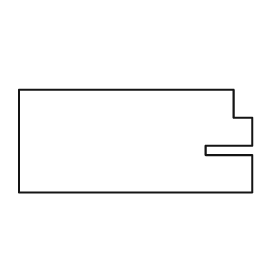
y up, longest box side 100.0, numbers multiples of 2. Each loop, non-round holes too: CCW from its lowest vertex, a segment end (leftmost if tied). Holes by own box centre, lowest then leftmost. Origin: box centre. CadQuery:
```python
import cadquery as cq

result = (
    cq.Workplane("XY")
    .moveTo(-50.0, -22.0)
    .lineTo(50.0, -22.0)
    .lineTo(50.0, -6.0)
    .lineTo(30.0, -6.0)
    .lineTo(30.0, -2.0)
    .lineTo(50.0, -2.0)
    .lineTo(50.0, 10.0)
    .lineTo(42.0, 10.0)
    .lineTo(42.0, 22.0)
    .lineTo(-50.0, 22.0)
    .close()
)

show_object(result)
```